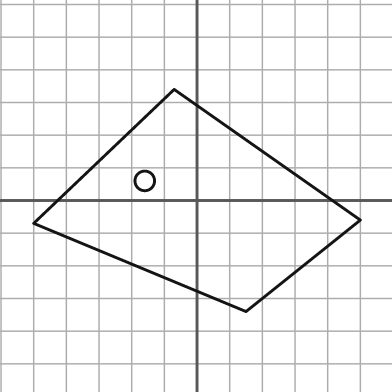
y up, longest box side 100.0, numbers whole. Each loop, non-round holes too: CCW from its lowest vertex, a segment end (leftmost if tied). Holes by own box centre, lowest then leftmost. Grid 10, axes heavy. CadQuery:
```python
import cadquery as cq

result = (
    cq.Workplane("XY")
    .moveTo(15.0, -34.0)
    .lineTo(50.0, -6.0)
    .lineTo(-7.0, 34.0)
    .lineTo(-50.0, -7.0)
    .close()
    .moveTo(-16.0, 6.0)
    .circle(3.0)
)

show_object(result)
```